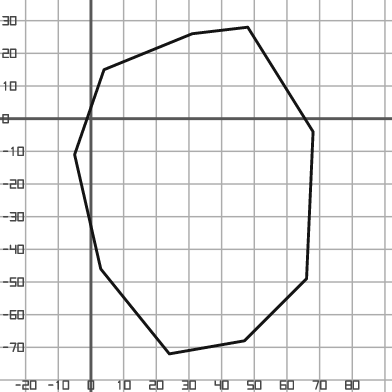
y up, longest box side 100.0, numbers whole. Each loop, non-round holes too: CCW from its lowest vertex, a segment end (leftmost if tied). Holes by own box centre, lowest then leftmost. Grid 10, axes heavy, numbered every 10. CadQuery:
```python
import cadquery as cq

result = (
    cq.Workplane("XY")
    .moveTo(24.0, -72.0)
    .lineTo(47.0, -68.0)
    .lineTo(66.0, -49.0)
    .lineTo(68.0, -4.0)
    .lineTo(48.0, 28.0)
    .lineTo(31.0, 26.0)
    .lineTo(4.0, 15.0)
    .lineTo(-5.0, -11.0)
    .lineTo(3.0, -46.0)
    .close()
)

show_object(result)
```